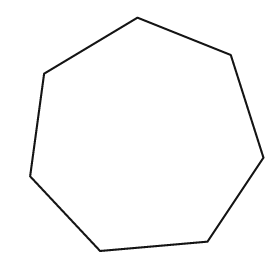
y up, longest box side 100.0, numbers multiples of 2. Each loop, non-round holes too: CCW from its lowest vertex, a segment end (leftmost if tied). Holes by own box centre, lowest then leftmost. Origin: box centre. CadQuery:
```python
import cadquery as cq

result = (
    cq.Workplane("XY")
    .moveTo(-20.0, -50.0)
    .lineTo(26.0, -46.0)
    .lineTo(50.0, -10.0)
    .lineTo(36.0, 34.0)
    .lineTo(-4.0, 50.0)
    .lineTo(-44.0, 26.0)
    .lineTo(-50.0, -18.0)
    .close()
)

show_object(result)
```